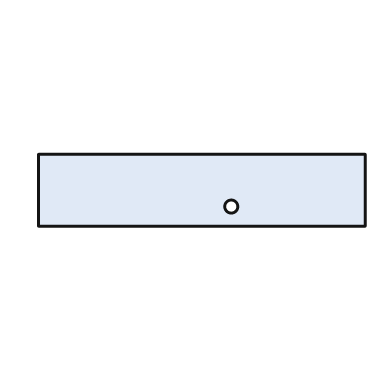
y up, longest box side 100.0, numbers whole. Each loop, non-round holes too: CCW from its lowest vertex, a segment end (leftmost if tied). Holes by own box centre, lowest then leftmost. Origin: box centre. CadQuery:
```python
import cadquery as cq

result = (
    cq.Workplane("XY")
    .moveTo(-50.0, -11.0)
    .lineTo(50.0, -11.0)
    .lineTo(50.0, 11.0)
    .lineTo(-50.0, 11.0)
    .close()
    .moveTo(9.0, -5.0)
    .circle(2.0)
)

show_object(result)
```